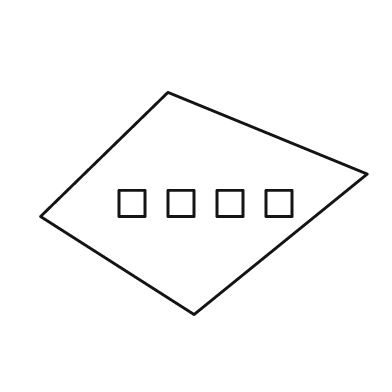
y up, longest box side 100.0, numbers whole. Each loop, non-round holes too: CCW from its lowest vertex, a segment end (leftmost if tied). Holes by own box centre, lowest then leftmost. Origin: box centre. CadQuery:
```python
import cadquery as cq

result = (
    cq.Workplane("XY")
    .moveTo(-3.0, -34.0)
    .lineTo(50.0, 9.0)
    .lineTo(-11.0, 34.0)
    .lineTo(-50.0, -4.0)
    .close()
    .moveTo(-26.0, -4.0)
    .lineTo(-18.0, -4.0)
    .lineTo(-18.0, 4.0)
    .lineTo(-26.0, 4.0)
    .close()
    .moveTo(-11.0, -4.0)
    .lineTo(-3.0, -4.0)
    .lineTo(-3.0, 4.0)
    .lineTo(-11.0, 4.0)
    .close()
    .moveTo(4.0, -4.0)
    .lineTo(12.0, -4.0)
    .lineTo(12.0, 4.0)
    .lineTo(4.0, 4.0)
    .close()
    .moveTo(19.0, -4.0)
    .lineTo(27.0, -4.0)
    .lineTo(27.0, 4.0)
    .lineTo(19.0, 4.0)
    .close()
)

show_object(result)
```